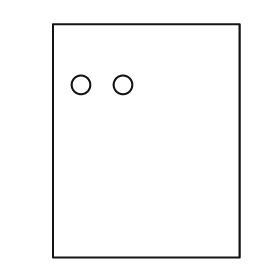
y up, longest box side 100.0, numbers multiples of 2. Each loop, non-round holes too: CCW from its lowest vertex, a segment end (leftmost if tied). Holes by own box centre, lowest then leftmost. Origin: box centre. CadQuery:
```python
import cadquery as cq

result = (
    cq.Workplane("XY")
    .moveTo(-40.0, -50.0)
    .lineTo(40.0, -50.0)
    .lineTo(40.0, 50.0)
    .lineTo(-40.0, 50.0)
    .close()
    .moveTo(-28.0, 24.0)
    .circle(4.0)
    .moveTo(-10.0, 24.0)
    .circle(4.0)
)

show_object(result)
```